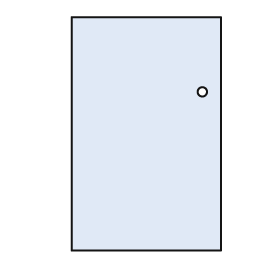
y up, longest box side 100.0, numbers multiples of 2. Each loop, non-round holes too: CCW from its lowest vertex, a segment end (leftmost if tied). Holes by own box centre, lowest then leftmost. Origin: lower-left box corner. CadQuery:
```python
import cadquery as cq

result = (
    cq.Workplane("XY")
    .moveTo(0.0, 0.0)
    .lineTo(64.0, 0.0)
    .lineTo(64.0, 100.0)
    .lineTo(0.0, 100.0)
    .close()
    .moveTo(56.0, 68.0)
    .circle(2.0)
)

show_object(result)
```